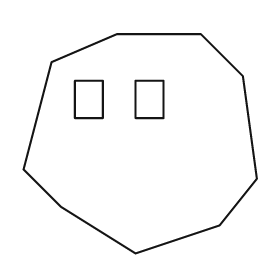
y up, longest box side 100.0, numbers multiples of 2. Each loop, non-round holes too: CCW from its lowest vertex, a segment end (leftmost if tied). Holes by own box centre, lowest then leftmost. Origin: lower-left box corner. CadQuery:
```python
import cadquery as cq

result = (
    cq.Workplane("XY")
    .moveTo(48.0, 0.0)
    .lineTo(84.0, 12.0)
    .lineTo(100.0, 32.0)
    .lineTo(94.0, 76.0)
    .lineTo(76.0, 94.0)
    .lineTo(40.0, 94.0)
    .lineTo(12.0, 82.0)
    .lineTo(0.0, 36.0)
    .lineTo(16.0, 20.0)
    .close()
    .moveTo(22.0, 58.0)
    .lineTo(34.0, 58.0)
    .lineTo(34.0, 74.0)
    .lineTo(22.0, 74.0)
    .close()
    .moveTo(48.0, 58.0)
    .lineTo(60.0, 58.0)
    .lineTo(60.0, 74.0)
    .lineTo(48.0, 74.0)
    .close()
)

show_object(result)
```